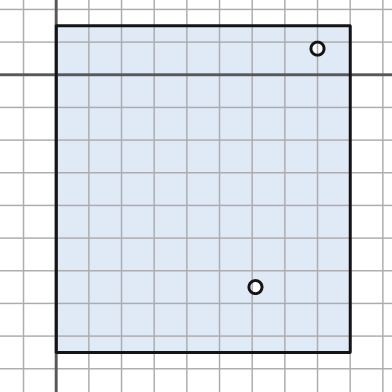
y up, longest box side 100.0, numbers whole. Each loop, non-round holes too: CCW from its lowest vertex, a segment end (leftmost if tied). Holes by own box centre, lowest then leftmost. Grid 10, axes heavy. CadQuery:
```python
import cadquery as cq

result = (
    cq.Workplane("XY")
    .moveTo(0.0, -85.0)
    .lineTo(90.0, -85.0)
    .lineTo(90.0, 15.0)
    .lineTo(0.0, 15.0)
    .close()
    .moveTo(61.0, -65.0)
    .circle(2.0)
    .moveTo(80.0, 8.0)
    .circle(2.0)
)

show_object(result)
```